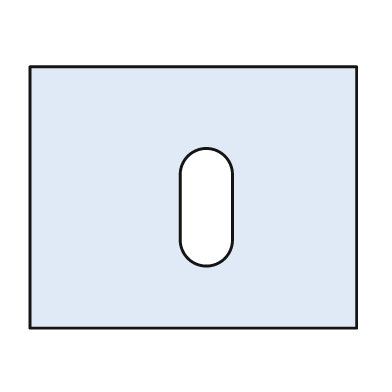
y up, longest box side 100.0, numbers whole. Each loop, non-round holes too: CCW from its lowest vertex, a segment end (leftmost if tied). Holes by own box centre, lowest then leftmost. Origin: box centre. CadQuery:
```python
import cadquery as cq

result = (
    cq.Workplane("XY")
    .moveTo(-50.0, -40.0)
    .lineTo(50.0, -40.0)
    .lineTo(50.0, 40.0)
    .lineTo(-50.0, 40.0)
    .close()
    .moveTo(-4.0, -13.0)
    .threePointArc((4.0, -21.0), (12.0, -13.0))
    .lineTo(12.0, 7.0)
    .threePointArc((4.0, 15.0), (-4.0, 7.0))
    .close()
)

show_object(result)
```